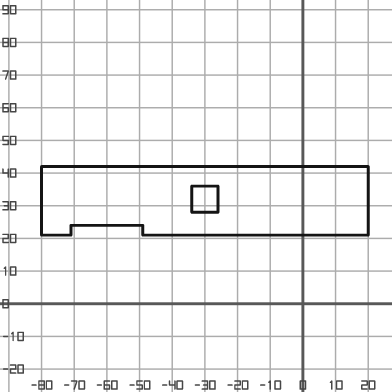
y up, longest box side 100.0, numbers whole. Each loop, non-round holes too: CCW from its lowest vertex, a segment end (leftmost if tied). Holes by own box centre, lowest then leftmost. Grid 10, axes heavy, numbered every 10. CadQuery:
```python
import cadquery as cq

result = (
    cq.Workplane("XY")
    .moveTo(-80.0, 21.0)
    .lineTo(-71.0, 21.0)
    .lineTo(-71.0, 24.0)
    .lineTo(-49.0, 24.0)
    .lineTo(-49.0, 21.0)
    .lineTo(20.0, 21.0)
    .lineTo(20.0, 42.0)
    .lineTo(-80.0, 42.0)
    .close()
    .moveTo(-34.0, 28.0)
    .lineTo(-26.0, 28.0)
    .lineTo(-26.0, 36.0)
    .lineTo(-34.0, 36.0)
    .close()
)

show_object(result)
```